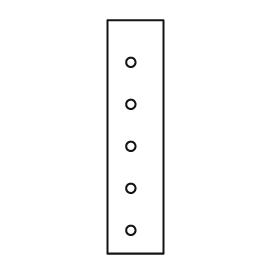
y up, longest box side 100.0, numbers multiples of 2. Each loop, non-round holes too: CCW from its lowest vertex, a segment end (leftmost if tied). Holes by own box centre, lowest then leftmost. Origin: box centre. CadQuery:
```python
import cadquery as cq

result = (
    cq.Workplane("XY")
    .moveTo(-12.0, -50.0)
    .lineTo(12.0, -50.0)
    .lineTo(12.0, 50.0)
    .lineTo(-12.0, 50.0)
    .close()
    .moveTo(-2.0, -40.0)
    .circle(2.0)
    .moveTo(-2.0, -22.0)
    .circle(2.0)
    .moveTo(-2.0, -4.0)
    .circle(2.0)
    .moveTo(-2.0, 14.0)
    .circle(2.0)
    .moveTo(-2.0, 32.0)
    .circle(2.0)
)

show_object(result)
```